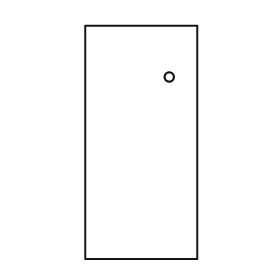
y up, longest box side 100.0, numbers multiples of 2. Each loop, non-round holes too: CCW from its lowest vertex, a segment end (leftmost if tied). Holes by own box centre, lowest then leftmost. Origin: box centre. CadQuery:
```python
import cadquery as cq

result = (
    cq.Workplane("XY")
    .moveTo(-24.0, -50.0)
    .lineTo(24.0, -50.0)
    .lineTo(24.0, 50.0)
    .lineTo(-24.0, 50.0)
    .close()
    .moveTo(12.0, 28.0)
    .circle(2.0)
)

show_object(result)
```